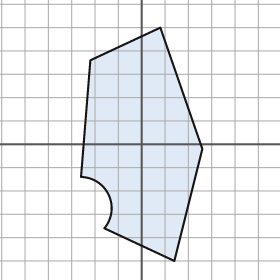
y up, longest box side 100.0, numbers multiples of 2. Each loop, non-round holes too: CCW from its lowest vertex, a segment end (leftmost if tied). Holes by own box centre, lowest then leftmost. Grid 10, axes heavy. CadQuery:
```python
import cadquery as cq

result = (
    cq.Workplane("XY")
    .moveTo(14.0, -50.0)
    .lineTo(26.0, -2.0)
    .lineTo(8.0, 50.0)
    .lineTo(-22.0, 36.0)
    .lineTo(-26.0, -14.0)
    .threePointArc((-14.0, -22.0), (-16.0, -36.0))
    .close()
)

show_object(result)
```